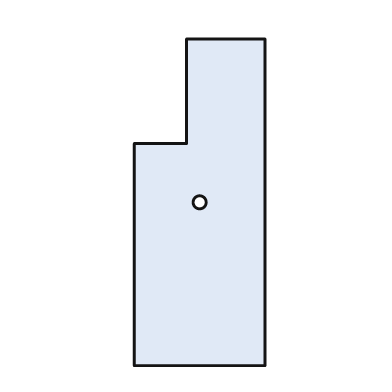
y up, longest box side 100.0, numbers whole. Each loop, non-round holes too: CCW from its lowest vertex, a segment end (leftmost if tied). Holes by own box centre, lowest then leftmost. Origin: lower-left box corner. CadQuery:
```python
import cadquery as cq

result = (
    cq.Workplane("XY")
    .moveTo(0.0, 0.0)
    .lineTo(40.0, 0.0)
    .lineTo(40.0, 100.0)
    .lineTo(16.0, 100.0)
    .lineTo(16.0, 68.0)
    .lineTo(0.0, 68.0)
    .close()
    .moveTo(20.0, 50.0)
    .circle(2.0)
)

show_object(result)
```